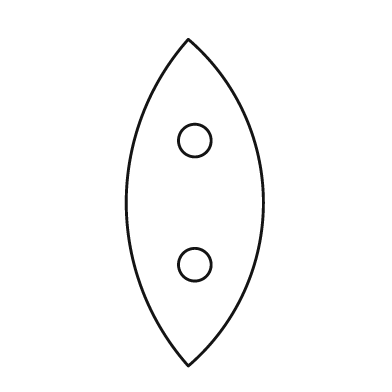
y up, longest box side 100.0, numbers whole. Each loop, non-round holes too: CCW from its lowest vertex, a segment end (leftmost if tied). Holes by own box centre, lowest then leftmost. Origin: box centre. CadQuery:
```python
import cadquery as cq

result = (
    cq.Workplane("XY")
    .moveTo(-2.0, -50.0)
    .threePointArc((21.0, 0.0), (-2.0, 50.0))
    .threePointArc((-21.0, 0.0), (-2.0, -50.0))
    .close()
    .moveTo(0.0, -19.0)
    .circle(5.0)
    .moveTo(0.0, 19.0)
    .circle(5.0)
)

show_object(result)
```